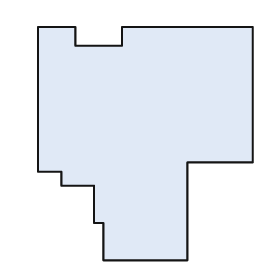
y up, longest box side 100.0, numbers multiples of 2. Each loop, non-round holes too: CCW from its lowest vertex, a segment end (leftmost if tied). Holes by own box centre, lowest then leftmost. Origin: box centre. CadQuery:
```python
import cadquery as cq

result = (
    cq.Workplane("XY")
    .moveTo(-18.0, -50.0)
    .lineTo(18.0, -50.0)
    .lineTo(18.0, -8.0)
    .lineTo(46.0, -8.0)
    .lineTo(46.0, 50.0)
    .lineTo(-10.0, 50.0)
    .lineTo(-10.0, 42.0)
    .lineTo(-30.0, 42.0)
    .lineTo(-30.0, 50.0)
    .lineTo(-46.0, 50.0)
    .lineTo(-46.0, -12.0)
    .lineTo(-36.0, -12.0)
    .lineTo(-36.0, -18.0)
    .lineTo(-22.0, -18.0)
    .lineTo(-22.0, -34.0)
    .lineTo(-18.0, -34.0)
    .close()
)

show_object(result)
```